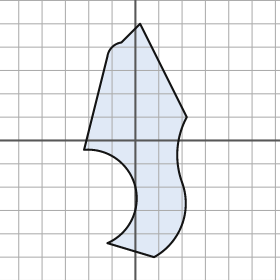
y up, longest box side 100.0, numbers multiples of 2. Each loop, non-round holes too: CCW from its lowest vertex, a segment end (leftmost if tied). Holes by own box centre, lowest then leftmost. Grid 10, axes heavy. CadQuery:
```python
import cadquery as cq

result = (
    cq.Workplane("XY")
    .moveTo(8.0, -50.0)
    .threePointArc((20.0, -36.0), (20.0, -18.0))
    .threePointArc((18.0, -4.0), (22.0, 10.0))
    .lineTo(2.0, 50.0)
    .lineTo(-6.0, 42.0)
    .threePointArc((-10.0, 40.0), (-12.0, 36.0))
    .lineTo(-22.0, -4.0)
    .threePointArc((0.0, -20.0), (-12.0, -44.0))
    .close()
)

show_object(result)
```